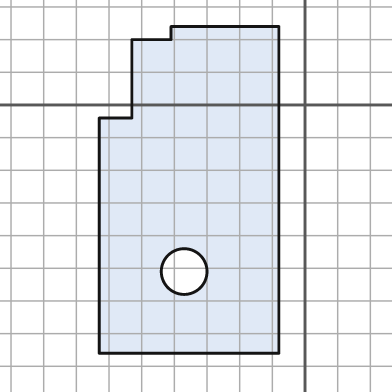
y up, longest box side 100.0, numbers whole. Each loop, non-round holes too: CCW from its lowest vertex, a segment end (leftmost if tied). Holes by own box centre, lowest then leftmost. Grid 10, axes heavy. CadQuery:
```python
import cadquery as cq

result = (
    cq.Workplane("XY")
    .moveTo(-63.0, -76.0)
    .lineTo(-8.0, -76.0)
    .lineTo(-8.0, 24.0)
    .lineTo(-41.0, 24.0)
    .lineTo(-41.0, 20.0)
    .lineTo(-53.0, 20.0)
    .lineTo(-53.0, -4.0)
    .lineTo(-63.0, -4.0)
    .close()
    .moveTo(-37.0, -51.0)
    .circle(7.0)
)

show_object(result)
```